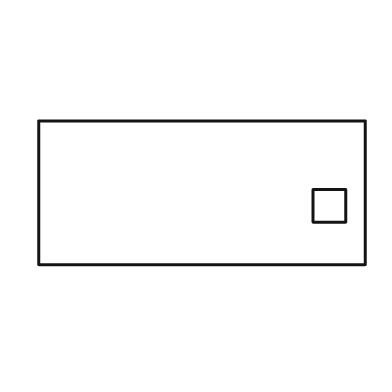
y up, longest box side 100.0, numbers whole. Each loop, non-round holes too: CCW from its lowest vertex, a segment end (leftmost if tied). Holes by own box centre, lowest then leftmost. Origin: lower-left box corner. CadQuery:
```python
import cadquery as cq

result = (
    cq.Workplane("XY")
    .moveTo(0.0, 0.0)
    .lineTo(100.0, 0.0)
    .lineTo(100.0, 44.0)
    .lineTo(0.0, 44.0)
    .close()
    .moveTo(84.0, 13.0)
    .lineTo(94.0, 13.0)
    .lineTo(94.0, 23.0)
    .lineTo(84.0, 23.0)
    .close()
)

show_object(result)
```